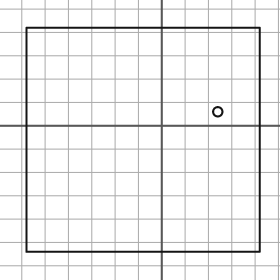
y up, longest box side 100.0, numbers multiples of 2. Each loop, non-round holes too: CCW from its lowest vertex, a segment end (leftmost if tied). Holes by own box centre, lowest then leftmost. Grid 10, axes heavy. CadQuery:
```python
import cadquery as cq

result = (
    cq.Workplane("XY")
    .moveTo(-58.0, -54.0)
    .lineTo(42.0, -54.0)
    .lineTo(42.0, 42.0)
    .lineTo(-58.0, 42.0)
    .close()
    .moveTo(24.0, 6.0)
    .circle(2.0)
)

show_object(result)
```